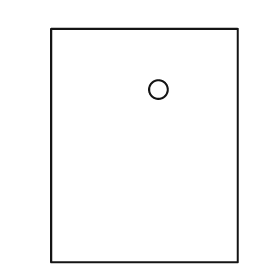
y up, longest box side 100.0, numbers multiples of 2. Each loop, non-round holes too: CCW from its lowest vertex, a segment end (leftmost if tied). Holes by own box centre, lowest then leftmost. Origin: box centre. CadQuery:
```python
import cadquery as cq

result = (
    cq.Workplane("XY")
    .moveTo(-40.0, -50.0)
    .lineTo(40.0, -50.0)
    .lineTo(40.0, 50.0)
    .lineTo(-40.0, 50.0)
    .close()
    .moveTo(6.0, 24.0)
    .circle(4.0)
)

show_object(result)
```